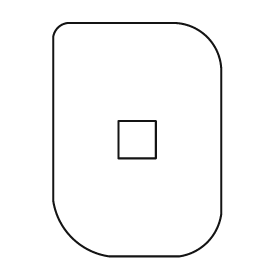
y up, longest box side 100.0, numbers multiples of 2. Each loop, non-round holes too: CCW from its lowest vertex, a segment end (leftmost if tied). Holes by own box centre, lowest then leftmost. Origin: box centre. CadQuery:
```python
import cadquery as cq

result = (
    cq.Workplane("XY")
    .moveTo(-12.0, -50.0)
    .lineTo(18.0, -50.0)
    .threePointArc((30.0, -44.0), (36.0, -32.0))
    .lineTo(36.0, 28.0)
    .threePointArc((30.0, 44.0), (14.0, 50.0))
    .lineTo(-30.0, 50.0)
    .threePointArc((-34.0, 48.0), (-36.0, 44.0))
    .lineTo(-36.0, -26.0)
    .threePointArc((-28.0, -42.0), (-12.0, -50.0))
    .close()
    .moveTo(-8.0, -8.0)
    .lineTo(8.0, -8.0)
    .lineTo(8.0, 8.0)
    .lineTo(-8.0, 8.0)
    .close()
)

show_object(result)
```